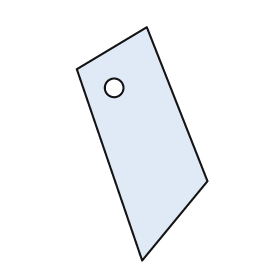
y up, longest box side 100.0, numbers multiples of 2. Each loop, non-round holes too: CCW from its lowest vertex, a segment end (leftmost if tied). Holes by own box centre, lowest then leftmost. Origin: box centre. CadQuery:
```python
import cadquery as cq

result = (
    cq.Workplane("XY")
    .moveTo(0.0, -50.0)
    .lineTo(28.0, -16.0)
    .lineTo(2.0, 50.0)
    .lineTo(-28.0, 32.0)
    .close()
    .moveTo(-12.0, 24.0)
    .circle(4.0)
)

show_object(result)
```